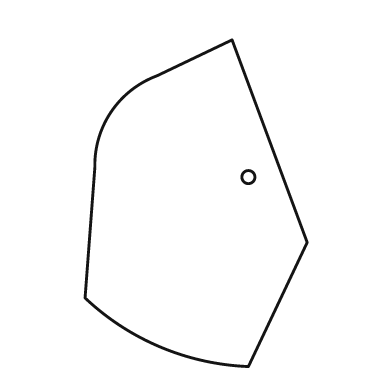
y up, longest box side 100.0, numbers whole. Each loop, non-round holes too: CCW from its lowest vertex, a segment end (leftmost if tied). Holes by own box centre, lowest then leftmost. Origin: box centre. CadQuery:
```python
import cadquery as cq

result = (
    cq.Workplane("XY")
    .moveTo(16.0, -50.0)
    .lineTo(34.0, -12.0)
    .lineTo(11.0, 50.0)
    .lineTo(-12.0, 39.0)
    .threePointArc((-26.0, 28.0), (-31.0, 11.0))
    .lineTo(-34.0, -29.0)
    .threePointArc((-11.0, -44.0), (16.0, -50.0))
    .close()
    .moveTo(16.0, 8.0)
    .circle(2.0)
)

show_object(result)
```